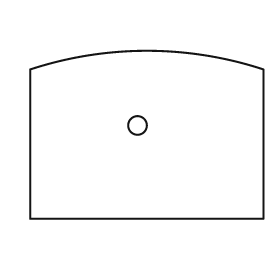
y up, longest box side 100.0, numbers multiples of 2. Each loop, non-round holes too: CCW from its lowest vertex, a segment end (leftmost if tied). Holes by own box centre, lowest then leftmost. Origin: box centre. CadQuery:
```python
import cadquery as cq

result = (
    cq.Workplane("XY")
    .moveTo(-50.0, -36.0)
    .lineTo(50.0, -36.0)
    .lineTo(50.0, 28.0)
    .threePointArc((0.0, 36.0), (-50.0, 28.0))
    .close()
    .moveTo(-4.0, 4.0)
    .circle(4.0)
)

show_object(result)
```